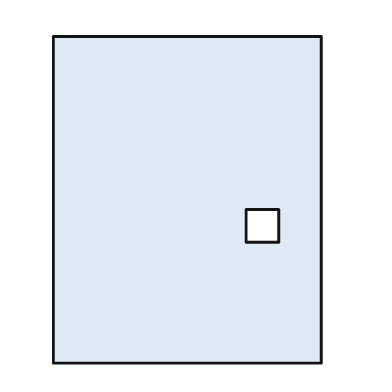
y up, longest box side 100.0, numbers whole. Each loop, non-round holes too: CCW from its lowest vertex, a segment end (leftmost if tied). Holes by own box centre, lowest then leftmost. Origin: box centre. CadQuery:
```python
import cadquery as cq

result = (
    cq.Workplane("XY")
    .moveTo(-41.0, -50.0)
    .lineTo(41.0, -50.0)
    .lineTo(41.0, 50.0)
    .lineTo(-41.0, 50.0)
    .close()
    .moveTo(18.0, -13.0)
    .lineTo(28.0, -13.0)
    .lineTo(28.0, -3.0)
    .lineTo(18.0, -3.0)
    .close()
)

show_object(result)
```